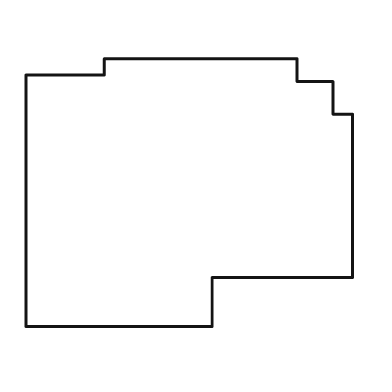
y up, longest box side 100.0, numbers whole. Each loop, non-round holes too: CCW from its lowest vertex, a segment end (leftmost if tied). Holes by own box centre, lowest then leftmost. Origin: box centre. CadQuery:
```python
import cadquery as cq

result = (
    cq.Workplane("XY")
    .moveTo(-50.0, -41.0)
    .lineTo(7.0, -41.0)
    .lineTo(7.0, -26.0)
    .lineTo(50.0, -26.0)
    .lineTo(50.0, 24.0)
    .lineTo(44.0, 24.0)
    .lineTo(44.0, 34.0)
    .lineTo(33.0, 34.0)
    .lineTo(33.0, 41.0)
    .lineTo(-26.0, 41.0)
    .lineTo(-26.0, 36.0)
    .lineTo(-50.0, 36.0)
    .close()
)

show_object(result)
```